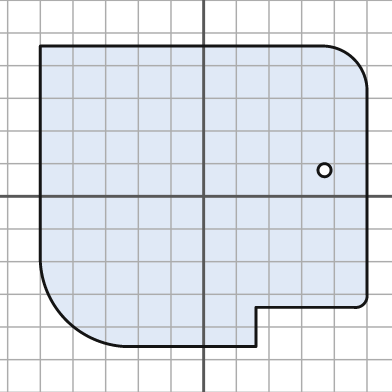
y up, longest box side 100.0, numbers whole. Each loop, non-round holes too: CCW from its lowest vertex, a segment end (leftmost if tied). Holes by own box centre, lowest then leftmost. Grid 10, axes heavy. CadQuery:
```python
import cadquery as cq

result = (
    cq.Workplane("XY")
    .moveTo(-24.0, -46.0)
    .lineTo(16.0, -46.0)
    .lineTo(16.0, -34.0)
    .lineTo(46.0, -34.0)
    .threePointArc((49.0, -33.0), (50.0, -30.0))
    .lineTo(50.0, 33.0)
    .threePointArc((46.0, 42.0), (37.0, 46.0))
    .lineTo(-50.0, 46.0)
    .lineTo(-50.0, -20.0)
    .threePointArc((-42.0, -38.0), (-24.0, -46.0))
    .close()
    .moveTo(37.0, 8.0)
    .circle(2.0)
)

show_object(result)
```